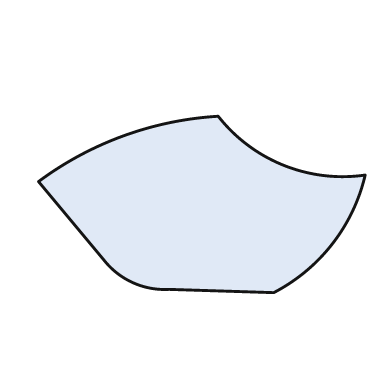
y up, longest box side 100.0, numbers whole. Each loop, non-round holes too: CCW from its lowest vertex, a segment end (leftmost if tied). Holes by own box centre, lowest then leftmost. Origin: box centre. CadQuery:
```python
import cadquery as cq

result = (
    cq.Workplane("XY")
    .moveTo(22.0, -27.0)
    .threePointArc((40.0, -12.0), (50.0, 9.0))
    .threePointArc((25.0, 12.0), (5.0, 27.0))
    .threePointArc((-24.0, 21.0), (-50.0, 7.0))
    .lineTo(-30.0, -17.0)
    .threePointArc((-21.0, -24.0), (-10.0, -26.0))
    .close()
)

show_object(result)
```